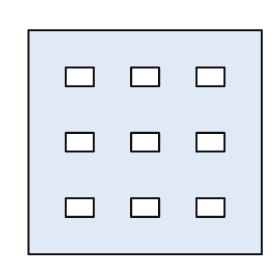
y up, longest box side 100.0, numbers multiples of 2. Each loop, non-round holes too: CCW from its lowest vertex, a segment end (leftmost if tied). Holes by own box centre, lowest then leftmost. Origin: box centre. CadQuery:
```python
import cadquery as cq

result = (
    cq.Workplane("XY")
    .moveTo(-50.0, -48.0)
    .lineTo(50.0, -48.0)
    .lineTo(50.0, 48.0)
    .lineTo(-50.0, 48.0)
    .close()
    .moveTo(-34.0, -32.0)
    .lineTo(-22.0, -32.0)
    .lineTo(-22.0, -24.0)
    .lineTo(-34.0, -24.0)
    .close()
    .moveTo(-6.0, -32.0)
    .lineTo(6.0, -32.0)
    .lineTo(6.0, -24.0)
    .lineTo(-6.0, -24.0)
    .close()
    .moveTo(22.0, -32.0)
    .lineTo(34.0, -32.0)
    .lineTo(34.0, -24.0)
    .lineTo(22.0, -24.0)
    .close()
    .moveTo(-34.0, -4.0)
    .lineTo(-22.0, -4.0)
    .lineTo(-22.0, 4.0)
    .lineTo(-34.0, 4.0)
    .close()
    .moveTo(-6.0, -4.0)
    .lineTo(6.0, -4.0)
    .lineTo(6.0, 4.0)
    .lineTo(-6.0, 4.0)
    .close()
    .moveTo(22.0, -4.0)
    .lineTo(34.0, -4.0)
    .lineTo(34.0, 4.0)
    .lineTo(22.0, 4.0)
    .close()
    .moveTo(-34.0, 24.0)
    .lineTo(-22.0, 24.0)
    .lineTo(-22.0, 32.0)
    .lineTo(-34.0, 32.0)
    .close()
    .moveTo(-6.0, 24.0)
    .lineTo(6.0, 24.0)
    .lineTo(6.0, 32.0)
    .lineTo(-6.0, 32.0)
    .close()
    .moveTo(22.0, 24.0)
    .lineTo(34.0, 24.0)
    .lineTo(34.0, 32.0)
    .lineTo(22.0, 32.0)
    .close()
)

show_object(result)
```